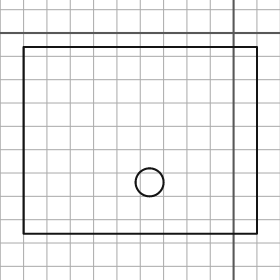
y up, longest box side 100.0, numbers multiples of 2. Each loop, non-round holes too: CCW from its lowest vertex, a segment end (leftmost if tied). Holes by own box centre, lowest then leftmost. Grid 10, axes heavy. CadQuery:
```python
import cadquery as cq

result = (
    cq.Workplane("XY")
    .moveTo(-90.0, -86.0)
    .lineTo(10.0, -86.0)
    .lineTo(10.0, -6.0)
    .lineTo(-90.0, -6.0)
    .close()
    .moveTo(-36.0, -64.0)
    .circle(6.0)
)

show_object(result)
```